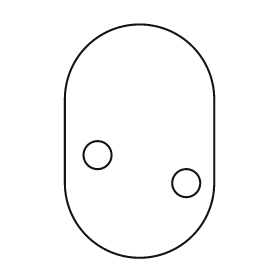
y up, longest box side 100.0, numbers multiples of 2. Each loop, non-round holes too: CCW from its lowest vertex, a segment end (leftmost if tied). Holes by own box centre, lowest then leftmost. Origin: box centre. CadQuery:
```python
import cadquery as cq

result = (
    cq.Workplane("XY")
    .moveTo(-32.0, -18.0)
    .threePointArc((0.0, -50.0), (32.0, -18.0))
    .lineTo(32.0, 18.0)
    .threePointArc((0.0, 50.0), (-32.0, 18.0))
    .close()
    .moveTo(20.0, -18.0)
    .circle(6.0)
    .moveTo(-18.0, -6.0)
    .circle(6.0)
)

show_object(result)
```